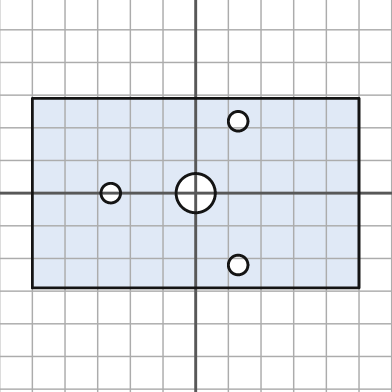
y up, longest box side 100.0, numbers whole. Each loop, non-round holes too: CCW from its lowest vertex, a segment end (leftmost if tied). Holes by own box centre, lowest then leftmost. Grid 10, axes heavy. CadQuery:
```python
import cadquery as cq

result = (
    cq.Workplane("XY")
    .moveTo(-50.0, -29.0)
    .lineTo(50.0, -29.0)
    .lineTo(50.0, 29.0)
    .lineTo(-50.0, 29.0)
    .close()
    .moveTo(13.0, -22.0)
    .circle(3.0)
    .moveTo(-26.0, 0.0)
    .circle(3.0)
    .moveTo(0.0, 0.0)
    .circle(6.0)
    .moveTo(13.0, 22.0)
    .circle(3.0)
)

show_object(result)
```